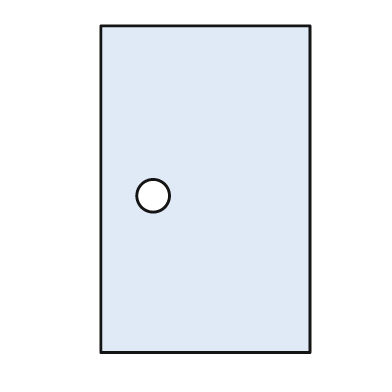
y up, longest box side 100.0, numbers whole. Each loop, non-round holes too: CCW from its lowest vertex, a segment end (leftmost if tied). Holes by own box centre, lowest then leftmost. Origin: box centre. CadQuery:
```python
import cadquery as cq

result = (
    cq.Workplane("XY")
    .moveTo(-32.0, -50.0)
    .lineTo(32.0, -50.0)
    .lineTo(32.0, 50.0)
    .lineTo(-32.0, 50.0)
    .close()
    .moveTo(-16.0, -2.0)
    .circle(5.0)
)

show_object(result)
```